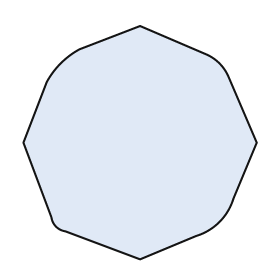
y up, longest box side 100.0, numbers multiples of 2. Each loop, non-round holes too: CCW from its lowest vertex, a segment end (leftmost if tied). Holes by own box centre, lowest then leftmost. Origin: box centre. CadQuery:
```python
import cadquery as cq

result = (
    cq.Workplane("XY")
    .moveTo(0.0, -50.0)
    .lineTo(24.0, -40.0)
    .threePointArc((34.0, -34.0), (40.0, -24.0))
    .lineTo(50.0, 0.0)
    .lineTo(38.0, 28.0)
    .threePointArc((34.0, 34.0), (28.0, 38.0))
    .lineTo(0.0, 50.0)
    .lineTo(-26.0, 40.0)
    .threePointArc((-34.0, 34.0), (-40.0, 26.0))
    .lineTo(-50.0, 0.0)
    .lineTo(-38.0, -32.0)
    .threePointArc((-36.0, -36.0), (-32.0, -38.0))
    .close()
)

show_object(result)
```